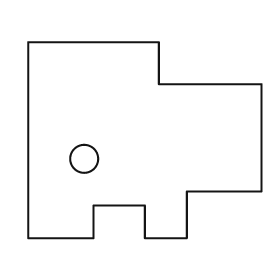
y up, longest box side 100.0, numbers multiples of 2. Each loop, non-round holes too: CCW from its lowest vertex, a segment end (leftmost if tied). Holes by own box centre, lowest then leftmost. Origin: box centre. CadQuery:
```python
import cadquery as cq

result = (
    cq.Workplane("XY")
    .moveTo(-50.0, -42.0)
    .lineTo(-22.0, -42.0)
    .lineTo(-22.0, -28.0)
    .lineTo(0.0, -28.0)
    .lineTo(0.0, -42.0)
    .lineTo(18.0, -42.0)
    .lineTo(18.0, -22.0)
    .lineTo(50.0, -22.0)
    .lineTo(50.0, 24.0)
    .lineTo(6.0, 24.0)
    .lineTo(6.0, 42.0)
    .lineTo(-50.0, 42.0)
    .close()
    .moveTo(-26.0, -8.0)
    .circle(6.0)
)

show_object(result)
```